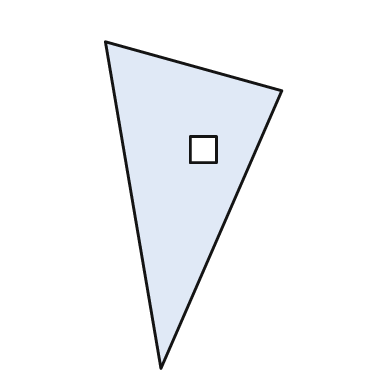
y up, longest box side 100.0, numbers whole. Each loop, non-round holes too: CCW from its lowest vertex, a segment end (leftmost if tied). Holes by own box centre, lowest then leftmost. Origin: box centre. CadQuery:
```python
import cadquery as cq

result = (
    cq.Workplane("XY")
    .moveTo(-10.0, -50.0)
    .lineTo(27.0, 35.0)
    .lineTo(-27.0, 50.0)
    .close()
    .moveTo(-1.0, 13.0)
    .lineTo(7.0, 13.0)
    .lineTo(7.0, 21.0)
    .lineTo(-1.0, 21.0)
    .close()
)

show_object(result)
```